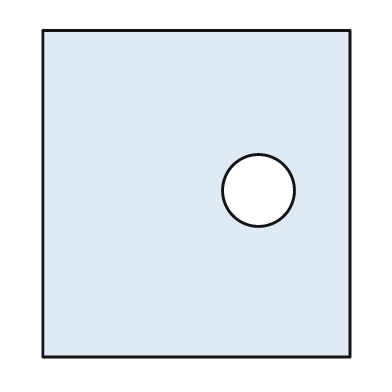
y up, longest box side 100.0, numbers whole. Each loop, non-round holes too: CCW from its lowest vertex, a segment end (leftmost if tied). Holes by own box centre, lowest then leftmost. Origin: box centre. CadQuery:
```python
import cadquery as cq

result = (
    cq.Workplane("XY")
    .moveTo(-47.0, -50.0)
    .lineTo(47.0, -50.0)
    .lineTo(47.0, 50.0)
    .lineTo(-47.0, 50.0)
    .close()
    .moveTo(19.0, 1.0)
    .circle(11.0)
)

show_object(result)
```